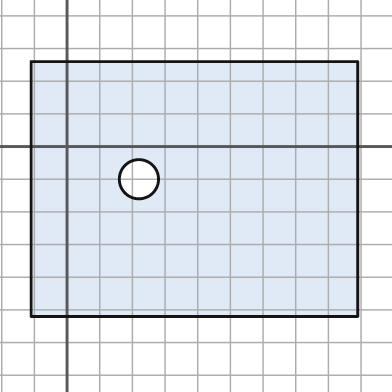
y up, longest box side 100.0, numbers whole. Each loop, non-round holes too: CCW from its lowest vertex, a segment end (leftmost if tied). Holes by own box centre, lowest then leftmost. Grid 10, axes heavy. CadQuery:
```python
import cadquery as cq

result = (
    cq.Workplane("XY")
    .moveTo(-11.0, -52.0)
    .lineTo(89.0, -52.0)
    .lineTo(89.0, 26.0)
    .lineTo(-11.0, 26.0)
    .close()
    .moveTo(22.0, -10.0)
    .circle(6.0)
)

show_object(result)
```